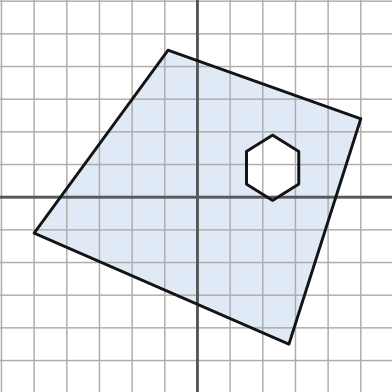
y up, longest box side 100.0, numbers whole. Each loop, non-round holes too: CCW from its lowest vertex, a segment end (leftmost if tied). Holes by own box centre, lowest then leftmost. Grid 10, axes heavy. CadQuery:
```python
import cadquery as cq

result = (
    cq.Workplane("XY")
    .moveTo(28.0, -45.0)
    .lineTo(50.0, 24.0)
    .lineTo(-9.0, 45.0)
    .lineTo(-50.0, -11.0)
    .close()
    .moveTo(23.0, -1.0)
    .lineTo(31.0, 4.0)
    .lineTo(31.0, 14.0)
    .lineTo(23.0, 19.0)
    .lineTo(15.0, 14.0)
    .lineTo(15.0, 4.0)
    .close()
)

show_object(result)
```